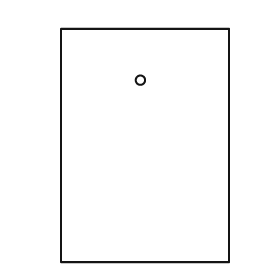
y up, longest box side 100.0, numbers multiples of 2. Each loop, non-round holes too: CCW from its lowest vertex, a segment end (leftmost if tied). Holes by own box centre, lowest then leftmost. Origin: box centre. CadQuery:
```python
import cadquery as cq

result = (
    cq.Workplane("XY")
    .moveTo(-36.0, -50.0)
    .lineTo(36.0, -50.0)
    .lineTo(36.0, 50.0)
    .lineTo(-36.0, 50.0)
    .close()
    .moveTo(-2.0, 28.0)
    .circle(2.0)
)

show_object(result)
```